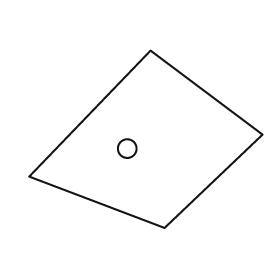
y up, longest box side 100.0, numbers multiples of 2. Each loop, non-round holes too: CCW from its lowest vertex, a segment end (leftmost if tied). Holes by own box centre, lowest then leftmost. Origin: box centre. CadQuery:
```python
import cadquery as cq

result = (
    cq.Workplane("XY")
    .moveTo(8.0, -38.0)
    .lineTo(50.0, 2.0)
    .lineTo(2.0, 38.0)
    .lineTo(-50.0, -16.0)
    .close()
    .moveTo(-8.0, -4.0)
    .circle(4.0)
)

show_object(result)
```